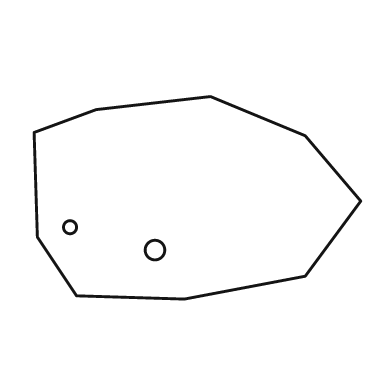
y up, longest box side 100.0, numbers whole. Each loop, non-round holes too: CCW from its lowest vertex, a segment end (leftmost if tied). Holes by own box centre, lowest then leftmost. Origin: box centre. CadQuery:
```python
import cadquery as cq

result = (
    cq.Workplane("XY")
    .moveTo(-4.0, -31.0)
    .lineTo(33.0, -24.0)
    .lineTo(50.0, -1.0)
    .lineTo(33.0, 19.0)
    .lineTo(4.0, 31.0)
    .lineTo(-31.0, 27.0)
    .lineTo(-50.0, 20.0)
    .lineTo(-49.0, -12.0)
    .lineTo(-37.0, -30.0)
    .close()
    .moveTo(-13.0, -16.0)
    .circle(3.0)
    .moveTo(-39.0, -9.0)
    .circle(2.0)
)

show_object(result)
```